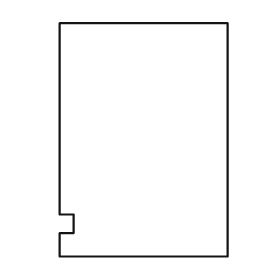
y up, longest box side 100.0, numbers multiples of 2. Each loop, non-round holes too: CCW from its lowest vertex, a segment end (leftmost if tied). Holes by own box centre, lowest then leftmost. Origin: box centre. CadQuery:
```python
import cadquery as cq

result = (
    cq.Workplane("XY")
    .moveTo(-36.0, -50.0)
    .lineTo(36.0, -50.0)
    .lineTo(36.0, 50.0)
    .lineTo(-36.0, 50.0)
    .lineTo(-36.0, -32.0)
    .lineTo(-30.0, -32.0)
    .lineTo(-30.0, -40.0)
    .lineTo(-36.0, -40.0)
    .close()
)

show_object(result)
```